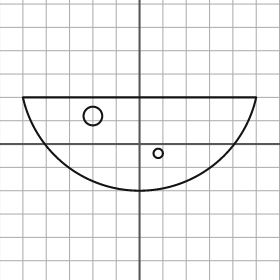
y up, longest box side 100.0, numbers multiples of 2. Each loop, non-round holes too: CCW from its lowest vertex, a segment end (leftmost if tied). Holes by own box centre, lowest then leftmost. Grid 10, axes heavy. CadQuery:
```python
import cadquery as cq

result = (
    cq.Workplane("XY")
    .moveTo(-50.0, 20.0)
    .threePointArc((0.0, -20.0), (50.0, 20.0))
    .close()
    .moveTo(8.0, -4.0)
    .circle(2.0)
    .moveTo(-20.0, 12.0)
    .circle(4.0)
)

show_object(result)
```